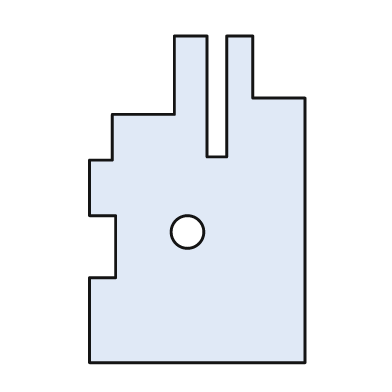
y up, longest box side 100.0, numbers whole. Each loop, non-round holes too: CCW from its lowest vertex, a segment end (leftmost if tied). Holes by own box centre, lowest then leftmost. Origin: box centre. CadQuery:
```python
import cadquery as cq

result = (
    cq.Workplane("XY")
    .moveTo(-33.0, -50.0)
    .lineTo(33.0, -50.0)
    .lineTo(33.0, 31.0)
    .lineTo(17.0, 31.0)
    .lineTo(17.0, 50.0)
    .lineTo(9.0, 50.0)
    .lineTo(9.0, 13.0)
    .lineTo(3.0, 13.0)
    .lineTo(3.0, 50.0)
    .lineTo(-7.0, 50.0)
    .lineTo(-7.0, 26.0)
    .lineTo(-26.0, 26.0)
    .lineTo(-26.0, 12.0)
    .lineTo(-33.0, 12.0)
    .lineTo(-33.0, -5.0)
    .lineTo(-25.0, -5.0)
    .lineTo(-25.0, -24.0)
    .lineTo(-33.0, -24.0)
    .close()
    .moveTo(-3.0, -10.0)
    .circle(5.0)
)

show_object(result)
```